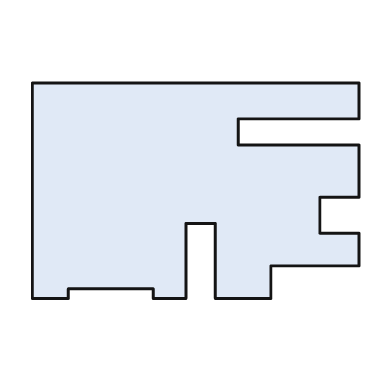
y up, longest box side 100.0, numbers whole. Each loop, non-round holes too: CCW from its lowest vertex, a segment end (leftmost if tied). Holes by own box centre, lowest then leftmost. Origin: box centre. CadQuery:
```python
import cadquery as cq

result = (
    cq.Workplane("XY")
    .moveTo(-50.0, -33.0)
    .lineTo(-39.0, -33.0)
    .lineTo(-39.0, -30.0)
    .lineTo(-13.0, -30.0)
    .lineTo(-13.0, -33.0)
    .lineTo(-3.0, -33.0)
    .lineTo(-3.0, -10.0)
    .lineTo(6.0, -10.0)
    .lineTo(6.0, -33.0)
    .lineTo(23.0, -33.0)
    .lineTo(23.0, -23.0)
    .lineTo(50.0, -23.0)
    .lineTo(50.0, -13.0)
    .lineTo(38.0, -13.0)
    .lineTo(38.0, -2.0)
    .lineTo(50.0, -2.0)
    .lineTo(50.0, 14.0)
    .lineTo(13.0, 14.0)
    .lineTo(13.0, 22.0)
    .lineTo(50.0, 22.0)
    .lineTo(50.0, 33.0)
    .lineTo(-50.0, 33.0)
    .close()
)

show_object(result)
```